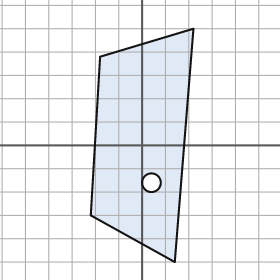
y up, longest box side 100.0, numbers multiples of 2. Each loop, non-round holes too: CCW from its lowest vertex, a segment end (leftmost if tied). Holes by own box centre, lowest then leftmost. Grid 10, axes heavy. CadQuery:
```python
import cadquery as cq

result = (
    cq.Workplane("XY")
    .moveTo(14.0, -50.0)
    .lineTo(22.0, 50.0)
    .lineTo(-18.0, 38.0)
    .lineTo(-22.0, -30.0)
    .close()
    .moveTo(4.0, -16.0)
    .circle(4.0)
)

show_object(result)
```